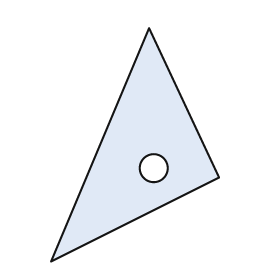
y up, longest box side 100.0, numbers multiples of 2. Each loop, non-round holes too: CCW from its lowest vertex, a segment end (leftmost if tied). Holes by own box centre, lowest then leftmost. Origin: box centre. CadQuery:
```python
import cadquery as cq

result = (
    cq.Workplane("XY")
    .moveTo(-36.0, -50.0)
    .lineTo(36.0, -14.0)
    .lineTo(6.0, 50.0)
    .close()
    .moveTo(8.0, -10.0)
    .circle(6.0)
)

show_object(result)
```